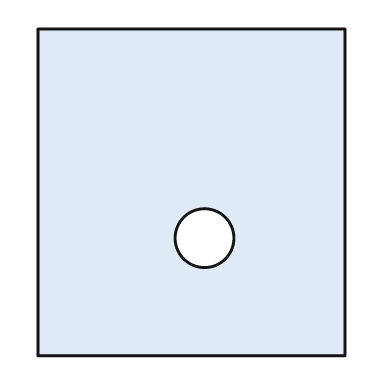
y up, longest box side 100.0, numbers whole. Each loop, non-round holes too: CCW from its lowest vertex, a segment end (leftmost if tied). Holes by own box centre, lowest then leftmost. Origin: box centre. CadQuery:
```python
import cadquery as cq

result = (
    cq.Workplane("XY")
    .moveTo(-47.0, -50.0)
    .lineTo(47.0, -50.0)
    .lineTo(47.0, 50.0)
    .lineTo(-47.0, 50.0)
    .close()
    .moveTo(4.0, -14.0)
    .circle(9.0)
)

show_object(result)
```